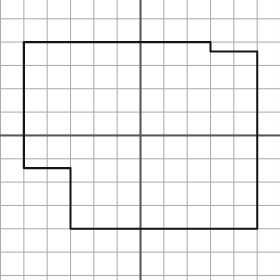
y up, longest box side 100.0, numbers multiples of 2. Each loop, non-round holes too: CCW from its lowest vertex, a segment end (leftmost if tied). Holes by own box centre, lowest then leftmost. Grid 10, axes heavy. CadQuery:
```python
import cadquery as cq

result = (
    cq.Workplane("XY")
    .moveTo(-30.0, -40.0)
    .lineTo(50.0, -40.0)
    .lineTo(50.0, 36.0)
    .lineTo(30.0, 36.0)
    .lineTo(30.0, 40.0)
    .lineTo(-50.0, 40.0)
    .lineTo(-50.0, -14.0)
    .lineTo(-30.0, -14.0)
    .close()
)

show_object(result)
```